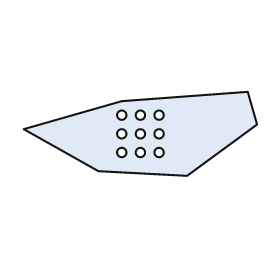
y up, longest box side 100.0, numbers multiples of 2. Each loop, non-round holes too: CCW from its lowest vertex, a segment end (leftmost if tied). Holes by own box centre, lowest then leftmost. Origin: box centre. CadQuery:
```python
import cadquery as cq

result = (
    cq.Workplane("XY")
    .moveTo(20.0, -18.0)
    .lineTo(50.0, 4.0)
    .lineTo(46.0, 18.0)
    .lineTo(-8.0, 14.0)
    .lineTo(-50.0, 2.0)
    .lineTo(-18.0, -16.0)
    .close()
    .moveTo(-8.0, -8.0)
    .circle(2.0)
    .moveTo(0.0, -8.0)
    .circle(2.0)
    .moveTo(8.0, -8.0)
    .circle(2.0)
    .moveTo(-8.0, 0.0)
    .circle(2.0)
    .moveTo(0.0, 0.0)
    .circle(2.0)
    .moveTo(8.0, 0.0)
    .circle(2.0)
    .moveTo(-8.0, 8.0)
    .circle(2.0)
    .moveTo(0.0, 8.0)
    .circle(2.0)
    .moveTo(8.0, 8.0)
    .circle(2.0)
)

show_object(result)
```